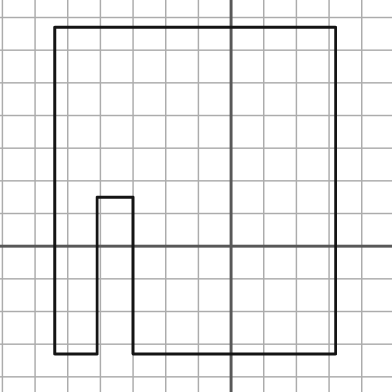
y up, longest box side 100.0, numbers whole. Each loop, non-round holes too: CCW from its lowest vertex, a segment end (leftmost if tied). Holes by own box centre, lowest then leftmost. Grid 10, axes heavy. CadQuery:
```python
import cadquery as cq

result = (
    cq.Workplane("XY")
    .moveTo(-54.0, -33.0)
    .lineTo(-41.0, -33.0)
    .lineTo(-41.0, 15.0)
    .lineTo(-30.0, 15.0)
    .lineTo(-30.0, -33.0)
    .lineTo(32.0, -33.0)
    .lineTo(32.0, 67.0)
    .lineTo(-54.0, 67.0)
    .close()
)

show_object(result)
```